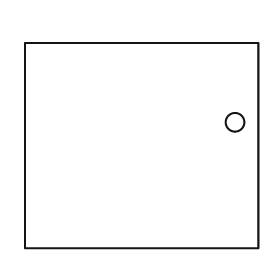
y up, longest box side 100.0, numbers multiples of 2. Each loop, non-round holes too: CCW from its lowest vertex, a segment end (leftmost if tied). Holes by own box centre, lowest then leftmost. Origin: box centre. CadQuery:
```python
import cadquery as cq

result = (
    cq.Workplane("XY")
    .moveTo(-50.0, -44.0)
    .lineTo(50.0, -44.0)
    .lineTo(50.0, 44.0)
    .lineTo(-50.0, 44.0)
    .close()
    .moveTo(40.0, 10.0)
    .circle(4.0)
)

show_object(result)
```